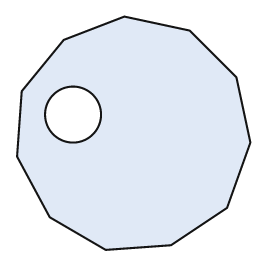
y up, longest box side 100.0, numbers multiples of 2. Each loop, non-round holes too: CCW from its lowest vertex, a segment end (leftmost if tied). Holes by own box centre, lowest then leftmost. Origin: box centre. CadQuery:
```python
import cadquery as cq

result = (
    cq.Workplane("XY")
    .moveTo(-12.0, -50.0)
    .lineTo(16.0, -48.0)
    .lineTo(40.0, -32.0)
    .lineTo(50.0, -4.0)
    .lineTo(44.0, 24.0)
    .lineTo(24.0, 44.0)
    .lineTo(-4.0, 50.0)
    .lineTo(-30.0, 40.0)
    .lineTo(-48.0, 18.0)
    .lineTo(-50.0, -10.0)
    .lineTo(-36.0, -36.0)
    .close()
    .moveTo(-26.0, 8.0)
    .circle(12.0)
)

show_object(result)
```